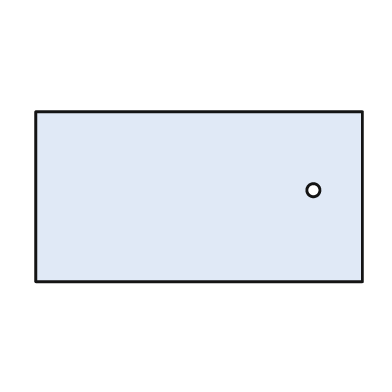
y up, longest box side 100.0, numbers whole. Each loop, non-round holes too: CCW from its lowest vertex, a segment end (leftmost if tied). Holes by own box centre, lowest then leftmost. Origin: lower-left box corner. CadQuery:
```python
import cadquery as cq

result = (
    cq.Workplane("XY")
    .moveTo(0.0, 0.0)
    .lineTo(100.0, 0.0)
    .lineTo(100.0, 52.0)
    .lineTo(0.0, 52.0)
    .close()
    .moveTo(85.0, 28.0)
    .circle(2.0)
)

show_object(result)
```